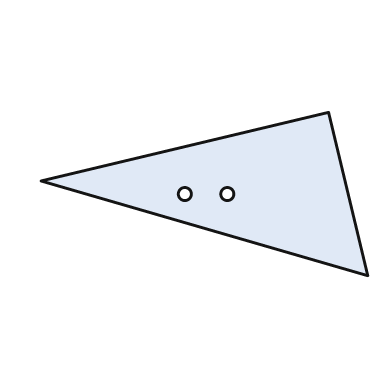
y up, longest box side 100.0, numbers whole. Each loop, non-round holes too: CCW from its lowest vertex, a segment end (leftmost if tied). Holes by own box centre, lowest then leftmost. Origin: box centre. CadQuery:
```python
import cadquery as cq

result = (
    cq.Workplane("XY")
    .moveTo(50.0, -25.0)
    .lineTo(38.0, 25.0)
    .lineTo(-50.0, 4.0)
    .close()
    .moveTo(-6.0, 0.0)
    .circle(2.0)
    .moveTo(7.0, 0.0)
    .circle(2.0)
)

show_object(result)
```